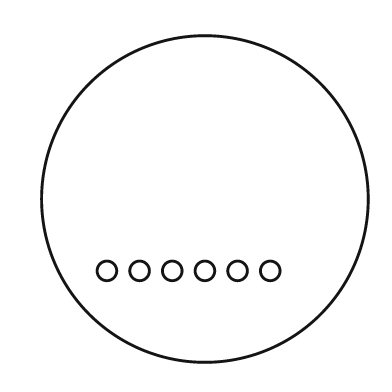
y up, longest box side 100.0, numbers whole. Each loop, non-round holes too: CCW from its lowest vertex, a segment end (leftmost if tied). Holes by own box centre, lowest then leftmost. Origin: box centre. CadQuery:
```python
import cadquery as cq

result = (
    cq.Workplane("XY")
    .moveTo(0.0, 0.0)
    .circle(50.0)
    .moveTo(-30.0, -22.0)
    .circle(3.0)
    .moveTo(-20.0, -22.0)
    .circle(3.0)
    .moveTo(-10.0, -22.0)
    .circle(3.0)
    .moveTo(0.0, -22.0)
    .circle(3.0)
    .moveTo(10.0, -22.0)
    .circle(3.0)
    .moveTo(20.0, -22.0)
    .circle(3.0)
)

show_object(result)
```